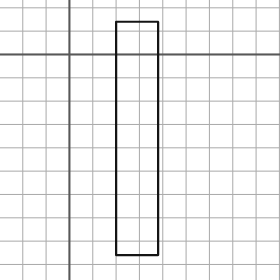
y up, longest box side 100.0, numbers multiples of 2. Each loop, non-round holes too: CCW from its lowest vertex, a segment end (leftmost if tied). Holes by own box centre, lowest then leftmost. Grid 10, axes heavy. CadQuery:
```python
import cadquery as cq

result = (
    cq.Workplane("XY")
    .moveTo(20.0, -86.0)
    .lineTo(38.0, -86.0)
    .lineTo(38.0, 14.0)
    .lineTo(20.0, 14.0)
    .close()
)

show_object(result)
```